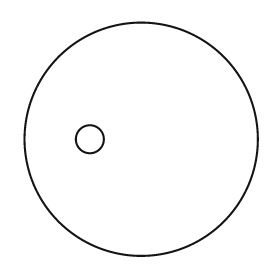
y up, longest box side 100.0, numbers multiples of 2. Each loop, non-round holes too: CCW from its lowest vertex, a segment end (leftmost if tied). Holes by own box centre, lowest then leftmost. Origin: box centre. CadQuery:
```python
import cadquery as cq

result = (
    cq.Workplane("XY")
    .moveTo(0.0, 0.0)
    .circle(50.0)
    .moveTo(-22.0, 0.0)
    .circle(6.0)
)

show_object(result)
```